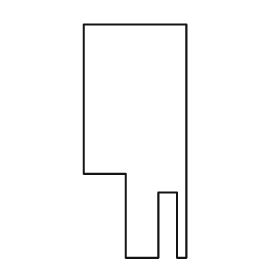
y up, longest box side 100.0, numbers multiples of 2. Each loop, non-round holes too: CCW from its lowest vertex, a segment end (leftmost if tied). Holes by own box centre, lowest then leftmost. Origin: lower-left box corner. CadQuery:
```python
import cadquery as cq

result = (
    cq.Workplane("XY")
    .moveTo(18.0, 0.0)
    .lineTo(32.0, 0.0)
    .lineTo(32.0, 28.0)
    .lineTo(40.0, 28.0)
    .lineTo(40.0, 0.0)
    .lineTo(44.0, 0.0)
    .lineTo(44.0, 100.0)
    .lineTo(0.0, 100.0)
    .lineTo(0.0, 36.0)
    .lineTo(18.0, 36.0)
    .close()
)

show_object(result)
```